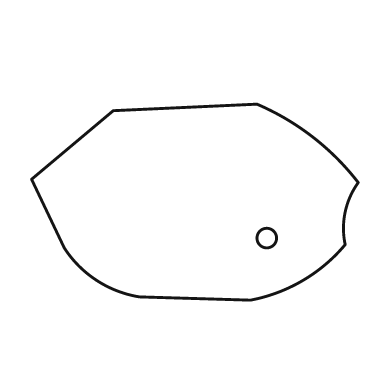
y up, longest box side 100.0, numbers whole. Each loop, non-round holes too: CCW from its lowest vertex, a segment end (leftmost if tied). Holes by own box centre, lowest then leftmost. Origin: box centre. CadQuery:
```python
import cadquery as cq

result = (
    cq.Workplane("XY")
    .moveTo(17.0, -30.0)
    .threePointArc((33.0, -24.0), (46.0, -13.0))
    .threePointArc((46.0, -3.0), (50.0, 6.0))
    .threePointArc((36.0, 20.0), (19.0, 30.0))
    .lineTo(-25.0, 28.0)
    .lineTo(-50.0, 7.0)
    .lineTo(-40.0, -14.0)
    .threePointArc((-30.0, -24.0), (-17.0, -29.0))
    .close()
    .moveTo(22.0, -11.0)
    .circle(3.0)
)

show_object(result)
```